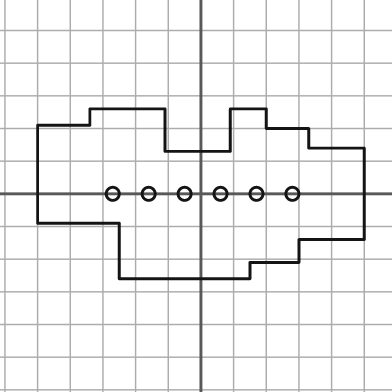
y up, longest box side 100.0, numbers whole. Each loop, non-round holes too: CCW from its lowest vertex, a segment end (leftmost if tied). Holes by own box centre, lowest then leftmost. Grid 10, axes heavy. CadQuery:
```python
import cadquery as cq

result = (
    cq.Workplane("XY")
    .moveTo(-25.0, -26.0)
    .lineTo(15.0, -26.0)
    .lineTo(15.0, -21.0)
    .lineTo(30.0, -21.0)
    .lineTo(30.0, -14.0)
    .lineTo(50.0, -14.0)
    .lineTo(50.0, 14.0)
    .lineTo(33.0, 14.0)
    .lineTo(33.0, 20.0)
    .lineTo(20.0, 20.0)
    .lineTo(20.0, 26.0)
    .lineTo(9.0, 26.0)
    .lineTo(9.0, 13.0)
    .lineTo(-11.0, 13.0)
    .lineTo(-11.0, 26.0)
    .lineTo(-34.0, 26.0)
    .lineTo(-34.0, 21.0)
    .lineTo(-50.0, 21.0)
    .lineTo(-50.0, -9.0)
    .lineTo(-25.0, -9.0)
    .close()
    .moveTo(-27.0, 0.0)
    .circle(2.0)
    .moveTo(-16.0, 0.0)
    .circle(2.0)
    .moveTo(-5.0, 0.0)
    .circle(2.0)
    .moveTo(6.0, 0.0)
    .circle(2.0)
    .moveTo(17.0, 0.0)
    .circle(2.0)
    .moveTo(28.0, 0.0)
    .circle(2.0)
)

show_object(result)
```